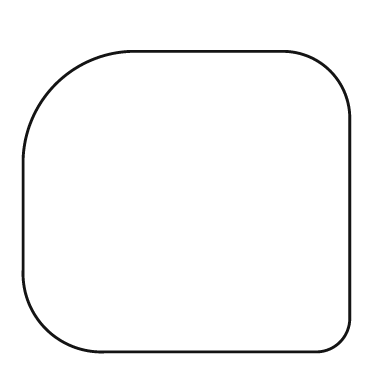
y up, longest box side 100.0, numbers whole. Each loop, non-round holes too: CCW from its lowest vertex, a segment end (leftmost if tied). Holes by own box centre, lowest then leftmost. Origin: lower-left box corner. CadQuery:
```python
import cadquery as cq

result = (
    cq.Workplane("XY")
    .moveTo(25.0, 0.0)
    .lineTo(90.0, 0.0)
    .threePointArc((97.0, 3.0), (100.0, 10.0))
    .lineTo(100.0, 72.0)
    .threePointArc((94.0, 86.0), (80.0, 92.0))
    .lineTo(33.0, 92.0)
    .threePointArc((10.0, 82.0), (0.0, 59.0))
    .lineTo(0.0, 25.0)
    .threePointArc((7.0, 7.0), (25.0, 0.0))
    .close()
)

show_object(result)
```